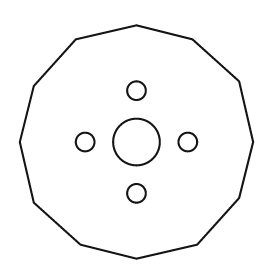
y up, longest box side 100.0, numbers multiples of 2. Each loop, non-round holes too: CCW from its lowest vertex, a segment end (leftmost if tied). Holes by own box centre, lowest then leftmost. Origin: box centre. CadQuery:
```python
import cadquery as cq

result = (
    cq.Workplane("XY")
    .moveTo(0.0, -50.0)
    .lineTo(26.0, -44.0)
    .lineTo(44.0, -24.0)
    .lineTo(50.0, 0.0)
    .lineTo(44.0, 26.0)
    .lineTo(24.0, 44.0)
    .lineTo(0.0, 50.0)
    .lineTo(-26.0, 44.0)
    .lineTo(-44.0, 24.0)
    .lineTo(-50.0, 0.0)
    .lineTo(-44.0, -26.0)
    .lineTo(-24.0, -44.0)
    .close()
    .moveTo(0.0, -22.0)
    .circle(4.0)
    .moveTo(-22.0, 0.0)
    .circle(4.0)
    .moveTo(0.0, 0.0)
    .circle(10.0)
    .moveTo(22.0, 0.0)
    .circle(4.0)
    .moveTo(0.0, 22.0)
    .circle(4.0)
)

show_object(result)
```